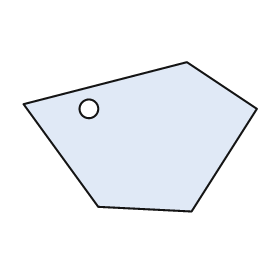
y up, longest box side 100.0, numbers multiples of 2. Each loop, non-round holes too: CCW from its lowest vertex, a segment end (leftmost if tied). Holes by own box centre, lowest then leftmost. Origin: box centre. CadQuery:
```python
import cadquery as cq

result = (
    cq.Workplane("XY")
    .moveTo(22.0, -32.0)
    .lineTo(50.0, 12.0)
    .lineTo(20.0, 32.0)
    .lineTo(-50.0, 14.0)
    .lineTo(-18.0, -30.0)
    .close()
    .moveTo(-22.0, 12.0)
    .circle(4.0)
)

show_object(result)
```